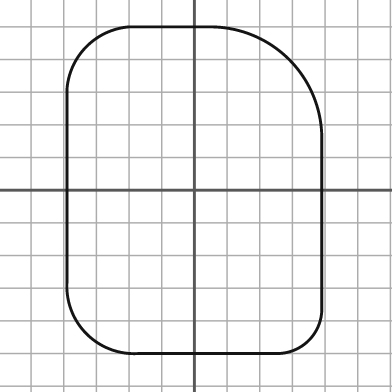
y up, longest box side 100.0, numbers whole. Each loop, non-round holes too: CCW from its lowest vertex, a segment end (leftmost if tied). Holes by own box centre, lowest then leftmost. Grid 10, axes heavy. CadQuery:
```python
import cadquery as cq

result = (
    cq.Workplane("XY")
    .moveTo(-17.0, -50.0)
    .lineTo(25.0, -50.0)
    .threePointArc((35.0, -46.0), (39.0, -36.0))
    .lineTo(39.0, 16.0)
    .threePointArc((29.0, 40.0), (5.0, 50.0))
    .lineTo(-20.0, 50.0)
    .threePointArc((-33.0, 44.0), (-39.0, 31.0))
    .lineTo(-39.0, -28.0)
    .threePointArc((-33.0, -44.0), (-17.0, -50.0))
    .close()
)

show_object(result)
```